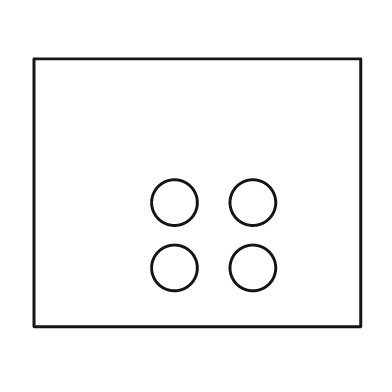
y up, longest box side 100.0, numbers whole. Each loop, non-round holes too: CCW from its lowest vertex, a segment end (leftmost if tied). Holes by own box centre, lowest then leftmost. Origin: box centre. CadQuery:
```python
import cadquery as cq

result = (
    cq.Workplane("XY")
    .moveTo(-50.0, -41.0)
    .lineTo(50.0, -41.0)
    .lineTo(50.0, 41.0)
    .lineTo(-50.0, 41.0)
    .close()
    .moveTo(-7.0, -23.0)
    .circle(7.0)
    .moveTo(17.0, -23.0)
    .circle(7.0)
    .moveTo(-7.0, -3.0)
    .circle(7.0)
    .moveTo(17.0, -3.0)
    .circle(7.0)
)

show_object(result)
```